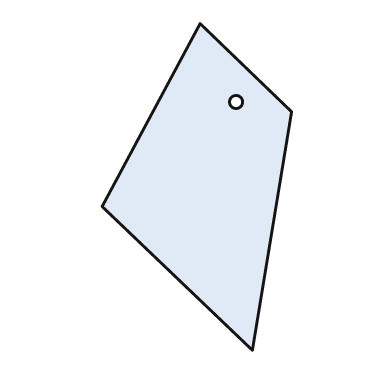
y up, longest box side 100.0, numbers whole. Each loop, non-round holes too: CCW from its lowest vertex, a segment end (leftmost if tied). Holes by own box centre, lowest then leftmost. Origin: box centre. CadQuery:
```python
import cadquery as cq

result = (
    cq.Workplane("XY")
    .moveTo(17.0, -50.0)
    .lineTo(29.0, 23.0)
    .lineTo(1.0, 50.0)
    .lineTo(-29.0, -6.0)
    .close()
    .moveTo(12.0, 26.0)
    .circle(2.0)
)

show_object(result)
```